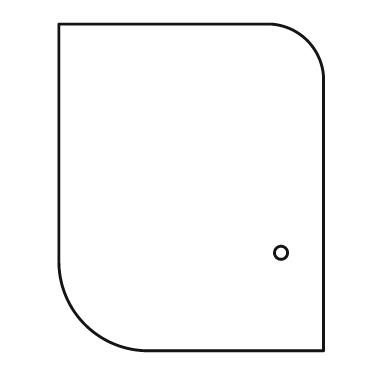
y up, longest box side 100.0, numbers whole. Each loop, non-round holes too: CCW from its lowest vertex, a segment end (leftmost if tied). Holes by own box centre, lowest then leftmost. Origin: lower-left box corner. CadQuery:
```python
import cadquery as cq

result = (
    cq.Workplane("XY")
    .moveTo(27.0, 0.0)
    .lineTo(81.0, 0.0)
    .lineTo(81.0, 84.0)
    .threePointArc((76.0, 95.0), (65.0, 100.0))
    .lineTo(0.0, 100.0)
    .lineTo(0.0, 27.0)
    .threePointArc((8.0, 8.0), (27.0, 0.0))
    .close()
    .moveTo(68.0, 30.0)
    .circle(2.0)
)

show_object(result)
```